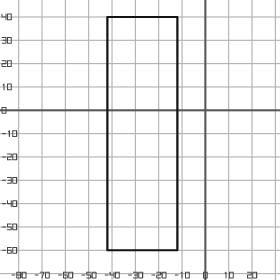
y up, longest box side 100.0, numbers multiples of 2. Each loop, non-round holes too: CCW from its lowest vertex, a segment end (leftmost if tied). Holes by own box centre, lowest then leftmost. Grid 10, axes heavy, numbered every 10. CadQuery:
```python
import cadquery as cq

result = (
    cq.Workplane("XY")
    .moveTo(-42.0, -60.0)
    .lineTo(-12.0, -60.0)
    .lineTo(-12.0, 40.0)
    .lineTo(-42.0, 40.0)
    .close()
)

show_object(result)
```